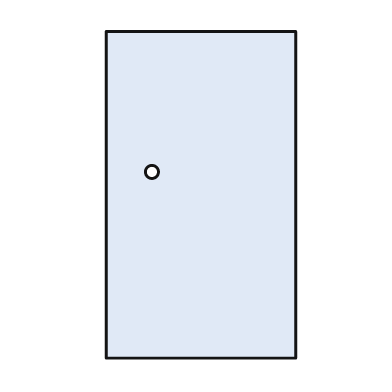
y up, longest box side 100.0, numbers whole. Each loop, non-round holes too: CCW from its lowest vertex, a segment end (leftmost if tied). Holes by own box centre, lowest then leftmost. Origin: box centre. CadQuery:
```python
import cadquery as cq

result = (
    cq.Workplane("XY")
    .moveTo(-29.0, -50.0)
    .lineTo(29.0, -50.0)
    .lineTo(29.0, 50.0)
    .lineTo(-29.0, 50.0)
    .close()
    .moveTo(-15.0, 7.0)
    .circle(2.0)
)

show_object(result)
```